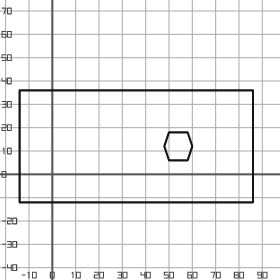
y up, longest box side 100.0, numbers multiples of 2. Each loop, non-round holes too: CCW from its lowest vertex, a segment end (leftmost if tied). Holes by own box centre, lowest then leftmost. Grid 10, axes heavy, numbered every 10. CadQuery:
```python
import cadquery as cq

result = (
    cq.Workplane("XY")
    .moveTo(-14.0, -12.0)
    .lineTo(86.0, -12.0)
    .lineTo(86.0, 36.0)
    .lineTo(-14.0, 36.0)
    .close()
    .moveTo(50.0, 6.0)
    .lineTo(58.0, 6.0)
    .lineTo(60.0, 12.0)
    .lineTo(58.0, 18.0)
    .lineTo(50.0, 18.0)
    .lineTo(48.0, 12.0)
    .close()
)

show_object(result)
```